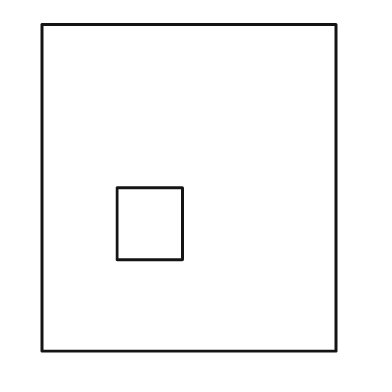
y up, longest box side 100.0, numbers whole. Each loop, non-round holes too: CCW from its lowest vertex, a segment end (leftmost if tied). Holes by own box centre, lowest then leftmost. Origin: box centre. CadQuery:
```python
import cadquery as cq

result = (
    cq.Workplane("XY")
    .moveTo(-45.0, -50.0)
    .lineTo(45.0, -50.0)
    .lineTo(45.0, 50.0)
    .lineTo(-45.0, 50.0)
    .close()
    .moveTo(-22.0, -22.0)
    .lineTo(-2.0, -22.0)
    .lineTo(-2.0, 0.0)
    .lineTo(-22.0, 0.0)
    .close()
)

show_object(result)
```